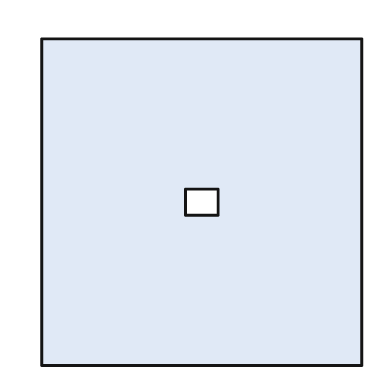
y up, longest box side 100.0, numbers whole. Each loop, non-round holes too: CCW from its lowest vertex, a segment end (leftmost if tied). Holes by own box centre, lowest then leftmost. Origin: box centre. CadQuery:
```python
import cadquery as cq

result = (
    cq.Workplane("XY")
    .moveTo(-49.0, -50.0)
    .lineTo(49.0, -50.0)
    .lineTo(49.0, 50.0)
    .lineTo(-49.0, 50.0)
    .close()
    .moveTo(-5.0, -4.0)
    .lineTo(5.0, -4.0)
    .lineTo(5.0, 4.0)
    .lineTo(-5.0, 4.0)
    .close()
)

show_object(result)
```